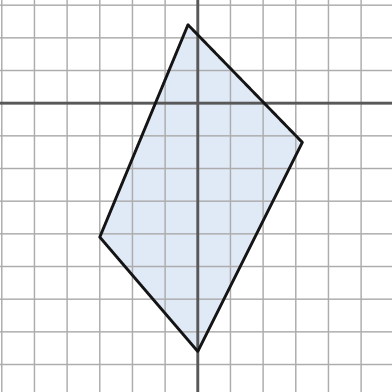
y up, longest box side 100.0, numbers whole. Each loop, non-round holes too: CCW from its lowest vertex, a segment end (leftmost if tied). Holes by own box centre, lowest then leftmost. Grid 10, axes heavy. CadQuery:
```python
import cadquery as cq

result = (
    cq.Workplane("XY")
    .moveTo(0.0, -76.0)
    .lineTo(32.0, -12.0)
    .lineTo(-3.0, 24.0)
    .lineTo(-30.0, -41.0)
    .close()
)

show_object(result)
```